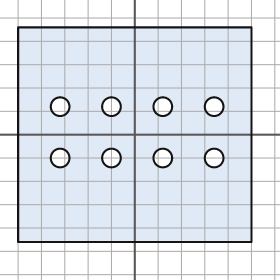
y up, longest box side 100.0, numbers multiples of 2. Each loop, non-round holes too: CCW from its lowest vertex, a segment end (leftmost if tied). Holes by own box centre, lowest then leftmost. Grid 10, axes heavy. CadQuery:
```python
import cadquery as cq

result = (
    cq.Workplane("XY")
    .moveTo(-50.0, -46.0)
    .lineTo(50.0, -46.0)
    .lineTo(50.0, 46.0)
    .lineTo(-50.0, 46.0)
    .close()
    .moveTo(-32.0, -10.0)
    .circle(4.0)
    .moveTo(-10.0, -10.0)
    .circle(4.0)
    .moveTo(12.0, -10.0)
    .circle(4.0)
    .moveTo(34.0, -10.0)
    .circle(4.0)
    .moveTo(-32.0, 12.0)
    .circle(4.0)
    .moveTo(-10.0, 12.0)
    .circle(4.0)
    .moveTo(12.0, 12.0)
    .circle(4.0)
    .moveTo(34.0, 12.0)
    .circle(4.0)
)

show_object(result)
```